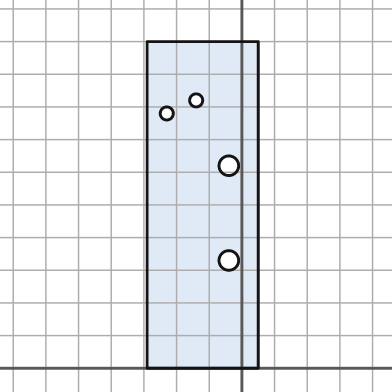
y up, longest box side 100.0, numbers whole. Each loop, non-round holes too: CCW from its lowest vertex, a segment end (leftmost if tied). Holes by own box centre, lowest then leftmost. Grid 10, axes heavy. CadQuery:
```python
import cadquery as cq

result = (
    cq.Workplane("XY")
    .moveTo(-29.0, 0.0)
    .lineTo(5.0, 0.0)
    .lineTo(5.0, 100.0)
    .lineTo(-29.0, 100.0)
    .close()
    .moveTo(-4.0, 33.0)
    .circle(3.0)
    .moveTo(-4.0, 62.0)
    .circle(3.0)
    .moveTo(-23.0, 78.0)
    .circle(2.0)
    .moveTo(-14.0, 82.0)
    .circle(2.0)
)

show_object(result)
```